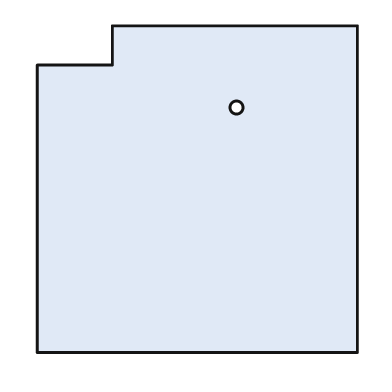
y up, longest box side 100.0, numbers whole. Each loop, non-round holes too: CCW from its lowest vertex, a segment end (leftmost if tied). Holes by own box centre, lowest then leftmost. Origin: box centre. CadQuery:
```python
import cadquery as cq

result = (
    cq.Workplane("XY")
    .moveTo(-49.0, -50.0)
    .lineTo(49.0, -50.0)
    .lineTo(49.0, 50.0)
    .lineTo(-26.0, 50.0)
    .lineTo(-26.0, 38.0)
    .lineTo(-49.0, 38.0)
    .close()
    .moveTo(12.0, 25.0)
    .circle(2.0)
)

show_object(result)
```